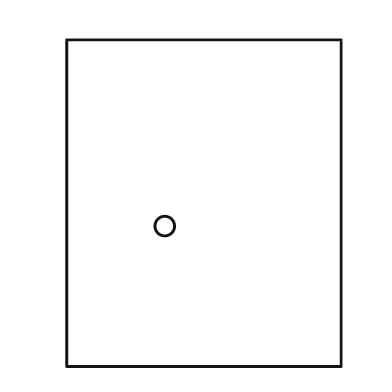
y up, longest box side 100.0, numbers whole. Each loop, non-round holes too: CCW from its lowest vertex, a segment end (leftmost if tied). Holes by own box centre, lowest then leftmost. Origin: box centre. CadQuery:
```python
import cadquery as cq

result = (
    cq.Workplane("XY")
    .moveTo(-42.0, -50.0)
    .lineTo(42.0, -50.0)
    .lineTo(42.0, 50.0)
    .lineTo(-42.0, 50.0)
    .close()
    .moveTo(-12.0, -7.0)
    .circle(3.0)
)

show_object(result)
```